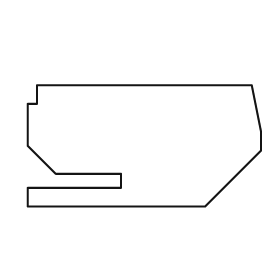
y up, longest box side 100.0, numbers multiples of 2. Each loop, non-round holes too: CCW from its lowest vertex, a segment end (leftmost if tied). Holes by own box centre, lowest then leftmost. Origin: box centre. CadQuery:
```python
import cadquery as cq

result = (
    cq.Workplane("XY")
    .moveTo(-50.0, -26.0)
    .lineTo(26.0, -26.0)
    .lineTo(50.0, -2.0)
    .lineTo(50.0, 6.0)
    .lineTo(46.0, 26.0)
    .lineTo(-46.0, 26.0)
    .lineTo(-46.0, 18.0)
    .lineTo(-50.0, 18.0)
    .lineTo(-50.0, 0.0)
    .lineTo(-38.0, -12.0)
    .lineTo(-10.0, -12.0)
    .lineTo(-10.0, -18.0)
    .lineTo(-50.0, -18.0)
    .close()
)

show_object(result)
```